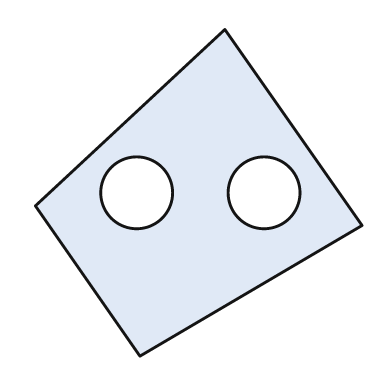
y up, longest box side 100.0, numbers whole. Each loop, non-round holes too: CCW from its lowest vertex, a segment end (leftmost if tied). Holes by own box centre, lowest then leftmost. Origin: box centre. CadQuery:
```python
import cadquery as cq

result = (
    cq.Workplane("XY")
    .moveTo(-18.0, -50.0)
    .lineTo(50.0, -10.0)
    .lineTo(8.0, 50.0)
    .lineTo(-50.0, -4.0)
    .close()
    .moveTo(-19.0, 0.0)
    .circle(11.0)
    .moveTo(20.0, 0.0)
    .circle(11.0)
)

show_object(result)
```